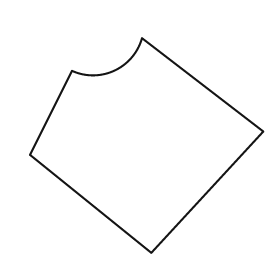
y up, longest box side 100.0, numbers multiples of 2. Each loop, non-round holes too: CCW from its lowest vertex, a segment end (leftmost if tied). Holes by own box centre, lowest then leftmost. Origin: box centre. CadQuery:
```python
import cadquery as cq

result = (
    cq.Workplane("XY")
    .moveTo(2.0, -46.0)
    .lineTo(50.0, 6.0)
    .lineTo(-2.0, 46.0)
    .threePointArc((-14.0, 32.0), (-32.0, 32.0))
    .lineTo(-50.0, -4.0)
    .close()
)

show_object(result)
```